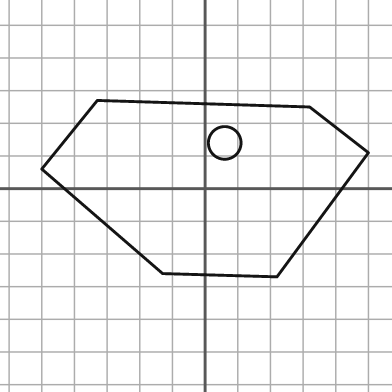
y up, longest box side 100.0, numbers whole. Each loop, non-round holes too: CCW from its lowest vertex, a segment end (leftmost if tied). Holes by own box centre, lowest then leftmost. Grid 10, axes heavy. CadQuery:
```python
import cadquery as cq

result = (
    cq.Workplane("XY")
    .moveTo(22.0, -27.0)
    .lineTo(50.0, 11.0)
    .lineTo(32.0, 25.0)
    .lineTo(-33.0, 27.0)
    .lineTo(-50.0, 6.0)
    .lineTo(-13.0, -26.0)
    .close()
    .moveTo(6.0, 14.0)
    .circle(5.0)
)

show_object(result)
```